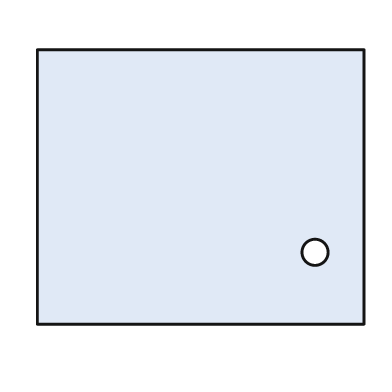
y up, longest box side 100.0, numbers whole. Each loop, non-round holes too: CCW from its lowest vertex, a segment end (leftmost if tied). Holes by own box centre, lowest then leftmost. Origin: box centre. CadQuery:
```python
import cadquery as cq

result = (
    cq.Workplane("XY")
    .moveTo(-50.0, -42.0)
    .lineTo(50.0, -42.0)
    .lineTo(50.0, 42.0)
    .lineTo(-50.0, 42.0)
    .close()
    .moveTo(35.0, -20.0)
    .circle(4.0)
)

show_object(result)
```